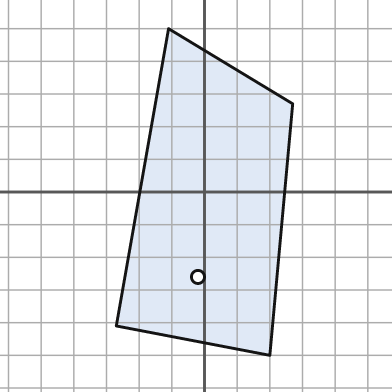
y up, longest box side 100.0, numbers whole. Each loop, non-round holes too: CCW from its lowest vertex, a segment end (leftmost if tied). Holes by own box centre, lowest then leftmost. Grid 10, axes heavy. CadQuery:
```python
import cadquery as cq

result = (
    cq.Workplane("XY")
    .moveTo(20.0, -50.0)
    .lineTo(27.0, 27.0)
    .lineTo(-11.0, 50.0)
    .lineTo(-27.0, -41.0)
    .close()
    .moveTo(-2.0, -26.0)
    .circle(2.0)
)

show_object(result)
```